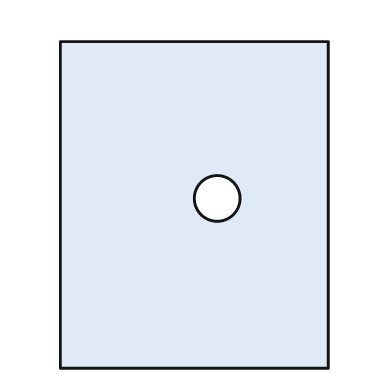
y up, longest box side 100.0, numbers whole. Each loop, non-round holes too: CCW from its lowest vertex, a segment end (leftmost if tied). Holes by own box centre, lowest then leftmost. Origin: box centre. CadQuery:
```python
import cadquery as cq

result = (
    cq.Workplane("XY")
    .moveTo(-41.0, -50.0)
    .lineTo(41.0, -50.0)
    .lineTo(41.0, 50.0)
    .lineTo(-41.0, 50.0)
    .close()
    .moveTo(7.0, 2.0)
    .circle(7.0)
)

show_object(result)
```